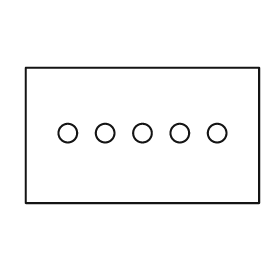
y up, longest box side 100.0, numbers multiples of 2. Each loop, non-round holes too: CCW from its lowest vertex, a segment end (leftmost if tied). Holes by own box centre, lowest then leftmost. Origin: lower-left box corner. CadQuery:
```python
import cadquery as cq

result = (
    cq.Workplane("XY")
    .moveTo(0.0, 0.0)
    .lineTo(100.0, 0.0)
    .lineTo(100.0, 58.0)
    .lineTo(0.0, 58.0)
    .close()
    .moveTo(18.0, 30.0)
    .circle(4.0)
    .moveTo(34.0, 30.0)
    .circle(4.0)
    .moveTo(50.0, 30.0)
    .circle(4.0)
    .moveTo(66.0, 30.0)
    .circle(4.0)
    .moveTo(82.0, 30.0)
    .circle(4.0)
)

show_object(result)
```